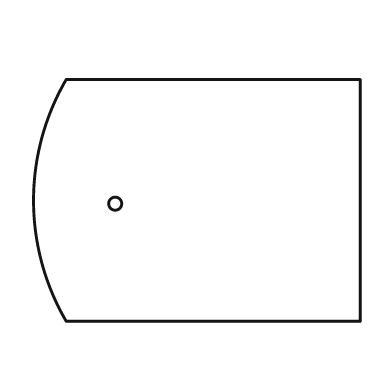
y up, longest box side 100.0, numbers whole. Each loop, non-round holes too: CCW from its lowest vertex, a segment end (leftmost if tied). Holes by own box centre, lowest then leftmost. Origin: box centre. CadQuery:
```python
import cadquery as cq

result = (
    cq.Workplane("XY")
    .moveTo(-40.0, -37.0)
    .lineTo(50.0, -37.0)
    .lineTo(50.0, 37.0)
    .lineTo(-40.0, 37.0)
    .threePointArc((-50.0, 0.0), (-40.0, -37.0))
    .close()
    .moveTo(-25.0, -1.0)
    .circle(2.0)
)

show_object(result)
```